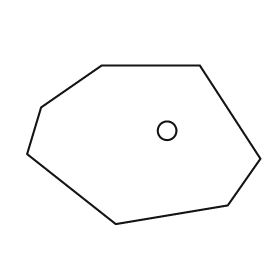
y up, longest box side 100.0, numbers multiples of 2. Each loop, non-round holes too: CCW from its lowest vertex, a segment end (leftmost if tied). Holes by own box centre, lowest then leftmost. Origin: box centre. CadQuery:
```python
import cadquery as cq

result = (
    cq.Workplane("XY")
    .moveTo(-12.0, -34.0)
    .lineTo(36.0, -26.0)
    .lineTo(50.0, -6.0)
    .lineTo(24.0, 34.0)
    .lineTo(-18.0, 34.0)
    .lineTo(-44.0, 16.0)
    .lineTo(-50.0, -4.0)
    .close()
    .moveTo(10.0, 6.0)
    .circle(4.0)
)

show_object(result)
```